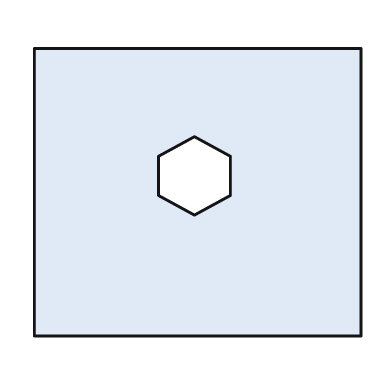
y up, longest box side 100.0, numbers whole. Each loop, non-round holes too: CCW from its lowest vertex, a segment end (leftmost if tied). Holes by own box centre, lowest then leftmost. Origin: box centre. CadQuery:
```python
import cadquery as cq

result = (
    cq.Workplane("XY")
    .moveTo(-50.0, -44.0)
    .lineTo(50.0, -44.0)
    .lineTo(50.0, 44.0)
    .lineTo(-50.0, 44.0)
    .close()
    .moveTo(-1.0, -7.0)
    .lineTo(10.0, -1.0)
    .lineTo(10.0, 11.0)
    .lineTo(-1.0, 17.0)
    .lineTo(-12.0, 11.0)
    .lineTo(-12.0, -1.0)
    .close()
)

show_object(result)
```